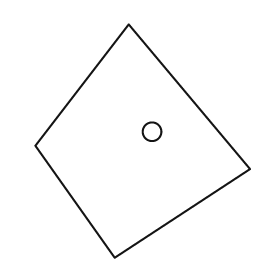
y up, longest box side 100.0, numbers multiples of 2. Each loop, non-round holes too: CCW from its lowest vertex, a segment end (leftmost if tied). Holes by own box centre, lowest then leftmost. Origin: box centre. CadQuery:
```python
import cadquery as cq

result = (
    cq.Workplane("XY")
    .moveTo(-12.0, -50.0)
    .lineTo(46.0, -12.0)
    .lineTo(-6.0, 50.0)
    .lineTo(-46.0, -2.0)
    .close()
    .moveTo(4.0, 4.0)
    .circle(4.0)
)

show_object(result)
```